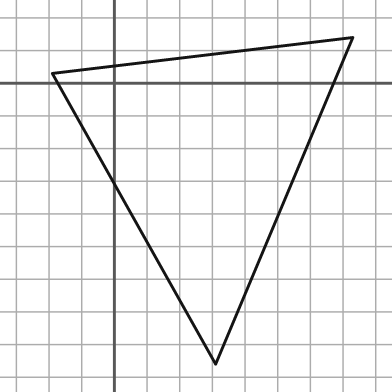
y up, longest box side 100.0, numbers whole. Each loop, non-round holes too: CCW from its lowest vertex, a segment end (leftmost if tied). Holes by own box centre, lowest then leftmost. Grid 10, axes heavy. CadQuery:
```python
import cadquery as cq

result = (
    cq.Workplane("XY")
    .moveTo(31.0, -86.0)
    .lineTo(73.0, 14.0)
    .lineTo(-19.0, 3.0)
    .close()
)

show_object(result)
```